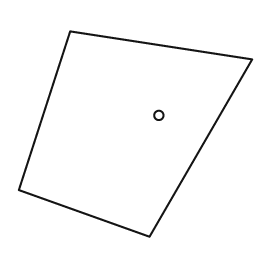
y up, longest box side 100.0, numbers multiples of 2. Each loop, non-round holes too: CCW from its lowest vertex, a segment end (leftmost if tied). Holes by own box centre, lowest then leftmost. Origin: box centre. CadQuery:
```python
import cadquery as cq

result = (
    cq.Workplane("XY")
    .moveTo(6.0, -44.0)
    .lineTo(50.0, 32.0)
    .lineTo(-28.0, 44.0)
    .lineTo(-50.0, -24.0)
    .close()
    .moveTo(10.0, 8.0)
    .circle(2.0)
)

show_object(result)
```